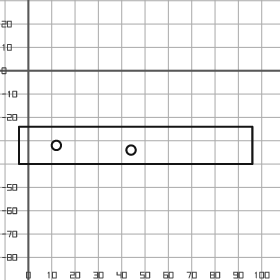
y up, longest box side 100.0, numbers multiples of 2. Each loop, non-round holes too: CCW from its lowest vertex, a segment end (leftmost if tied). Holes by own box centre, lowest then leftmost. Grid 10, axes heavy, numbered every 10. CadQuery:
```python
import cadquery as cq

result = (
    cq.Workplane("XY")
    .moveTo(-4.0, -40.0)
    .lineTo(96.0, -40.0)
    .lineTo(96.0, -24.0)
    .lineTo(-4.0, -24.0)
    .close()
    .moveTo(44.0, -34.0)
    .circle(2.0)
    .moveTo(12.0, -32.0)
    .circle(2.0)
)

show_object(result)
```